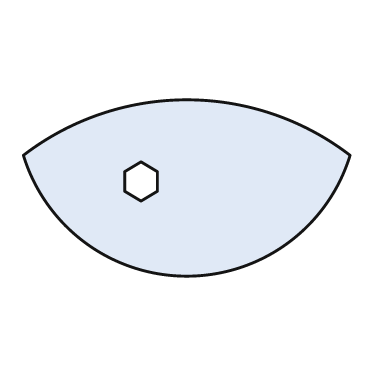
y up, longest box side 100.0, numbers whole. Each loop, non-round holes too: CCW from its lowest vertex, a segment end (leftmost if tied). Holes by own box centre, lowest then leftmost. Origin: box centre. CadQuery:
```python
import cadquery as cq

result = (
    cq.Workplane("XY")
    .moveTo(-50.0, 10.0)
    .threePointArc((0.0, -27.0), (50.0, 10.0))
    .threePointArc((0.0, 27.0), (-50.0, 10.0))
    .close()
    .moveTo(-14.0, -4.0)
    .lineTo(-9.0, -1.0)
    .lineTo(-9.0, 5.0)
    .lineTo(-14.0, 8.0)
    .lineTo(-19.0, 5.0)
    .lineTo(-19.0, -1.0)
    .close()
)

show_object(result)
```